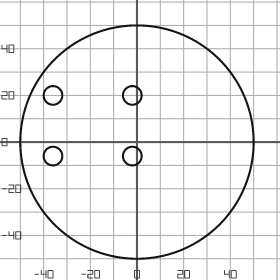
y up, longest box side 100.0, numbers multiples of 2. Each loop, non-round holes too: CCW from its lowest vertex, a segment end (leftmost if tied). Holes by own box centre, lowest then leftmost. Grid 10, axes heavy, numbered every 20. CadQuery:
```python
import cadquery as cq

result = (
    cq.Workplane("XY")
    .moveTo(0.0, 0.0)
    .circle(50.0)
    .moveTo(-36.0, -6.0)
    .circle(4.0)
    .moveTo(-2.0, -6.0)
    .circle(4.0)
    .moveTo(-36.0, 20.0)
    .circle(4.0)
    .moveTo(-2.0, 20.0)
    .circle(4.0)
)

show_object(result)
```